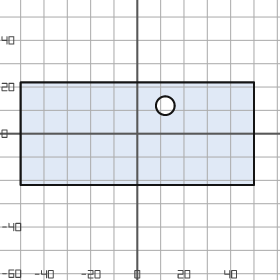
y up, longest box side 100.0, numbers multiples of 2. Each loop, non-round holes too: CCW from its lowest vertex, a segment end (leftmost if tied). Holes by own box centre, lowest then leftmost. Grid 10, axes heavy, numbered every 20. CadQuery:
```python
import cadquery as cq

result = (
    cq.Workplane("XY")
    .moveTo(-50.0, -22.0)
    .lineTo(50.0, -22.0)
    .lineTo(50.0, 22.0)
    .lineTo(-50.0, 22.0)
    .close()
    .moveTo(12.0, 12.0)
    .circle(4.0)
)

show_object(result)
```